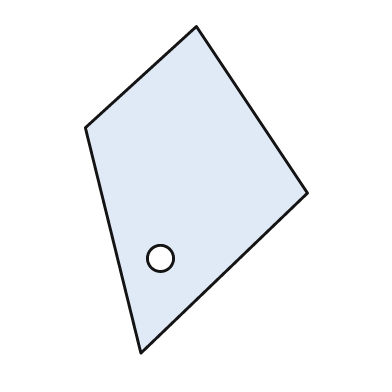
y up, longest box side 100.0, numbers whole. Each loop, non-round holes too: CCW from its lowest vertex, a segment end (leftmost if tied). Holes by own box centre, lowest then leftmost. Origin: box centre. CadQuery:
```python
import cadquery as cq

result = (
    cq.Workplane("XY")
    .moveTo(-17.0, -50.0)
    .lineTo(34.0, -1.0)
    .lineTo(0.0, 50.0)
    .lineTo(-34.0, 19.0)
    .close()
    .moveTo(-11.0, -21.0)
    .circle(4.0)
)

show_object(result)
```